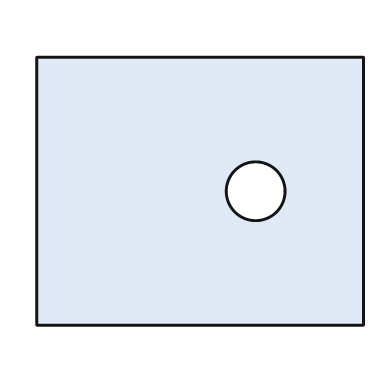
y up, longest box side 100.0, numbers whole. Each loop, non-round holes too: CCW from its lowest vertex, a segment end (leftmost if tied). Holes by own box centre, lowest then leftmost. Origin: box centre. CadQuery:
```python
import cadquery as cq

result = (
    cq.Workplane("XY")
    .moveTo(-50.0, -41.0)
    .lineTo(50.0, -41.0)
    .lineTo(50.0, 41.0)
    .lineTo(-50.0, 41.0)
    .close()
    .moveTo(17.0, 0.0)
    .circle(9.0)
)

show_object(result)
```